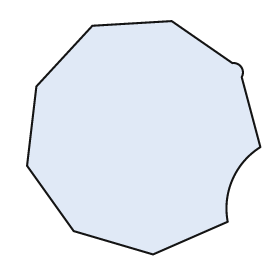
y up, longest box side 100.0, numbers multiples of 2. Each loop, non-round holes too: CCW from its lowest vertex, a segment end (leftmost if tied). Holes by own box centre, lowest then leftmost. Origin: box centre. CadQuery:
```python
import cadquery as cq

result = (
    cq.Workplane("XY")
    .moveTo(4.0, -50.0)
    .lineTo(36.0, -36.0)
    .threePointArc((38.0, -18.0), (50.0, -4.0))
    .lineTo(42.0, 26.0)
    .threePointArc((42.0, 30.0), (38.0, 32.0))
    .lineTo(12.0, 50.0)
    .lineTo(-22.0, 48.0)
    .lineTo(-46.0, 22.0)
    .lineTo(-50.0, -12.0)
    .lineTo(-30.0, -40.0)
    .close()
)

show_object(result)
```